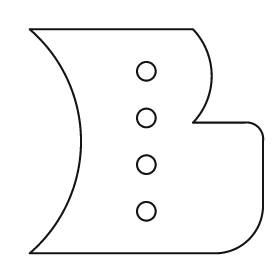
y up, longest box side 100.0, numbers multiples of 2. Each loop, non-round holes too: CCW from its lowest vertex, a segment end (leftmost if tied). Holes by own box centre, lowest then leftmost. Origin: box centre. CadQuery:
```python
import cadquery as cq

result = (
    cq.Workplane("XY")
    .moveTo(-50.0, -48.0)
    .lineTo(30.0, -48.0)
    .threePointArc((44.0, -42.0), (50.0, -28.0))
    .lineTo(50.0, 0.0)
    .threePointArc((48.0, 6.0), (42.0, 8.0))
    .lineTo(20.0, 8.0)
    .threePointArc((28.0, 28.0), (20.0, 48.0))
    .lineTo(-50.0, 48.0)
    .threePointArc((-28.0, 0.0), (-50.0, -48.0))
    .close()
    .moveTo(0.0, -30.0)
    .circle(4.0)
    .moveTo(0.0, -10.0)
    .circle(4.0)
    .moveTo(0.0, 10.0)
    .circle(4.0)
    .moveTo(0.0, 30.0)
    .circle(4.0)
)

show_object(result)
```